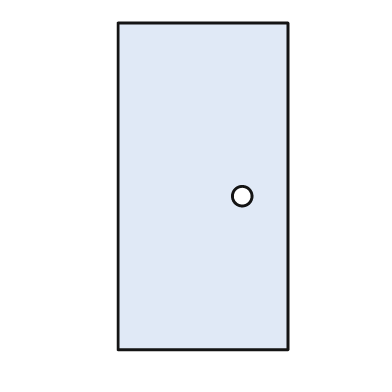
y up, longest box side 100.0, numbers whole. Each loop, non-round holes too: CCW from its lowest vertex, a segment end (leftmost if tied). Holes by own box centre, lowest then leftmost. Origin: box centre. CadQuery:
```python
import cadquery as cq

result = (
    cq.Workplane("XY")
    .moveTo(-26.0, -50.0)
    .lineTo(26.0, -50.0)
    .lineTo(26.0, 50.0)
    .lineTo(-26.0, 50.0)
    .close()
    .moveTo(12.0, -3.0)
    .circle(3.0)
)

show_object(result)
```